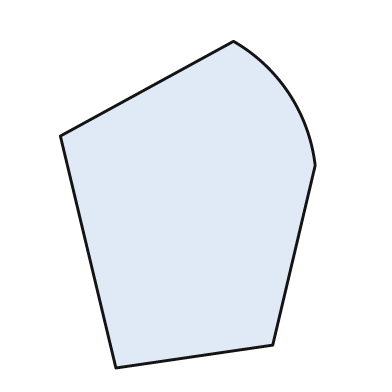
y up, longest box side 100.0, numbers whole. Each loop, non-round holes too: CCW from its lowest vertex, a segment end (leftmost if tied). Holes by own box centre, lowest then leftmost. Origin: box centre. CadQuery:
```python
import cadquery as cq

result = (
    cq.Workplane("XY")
    .moveTo(-22.0, -50.0)
    .lineTo(26.0, -43.0)
    .lineTo(39.0, 12.0)
    .threePointArc((31.0, 34.0), (14.0, 50.0))
    .lineTo(-39.0, 21.0)
    .close()
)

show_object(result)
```